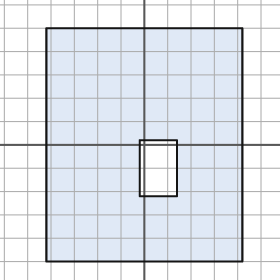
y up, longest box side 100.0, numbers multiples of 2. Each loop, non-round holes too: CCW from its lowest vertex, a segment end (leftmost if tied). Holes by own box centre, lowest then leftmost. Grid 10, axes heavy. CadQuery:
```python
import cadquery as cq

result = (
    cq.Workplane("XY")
    .moveTo(-42.0, -50.0)
    .lineTo(42.0, -50.0)
    .lineTo(42.0, 50.0)
    .lineTo(-42.0, 50.0)
    .close()
    .moveTo(-2.0, -22.0)
    .lineTo(14.0, -22.0)
    .lineTo(14.0, 2.0)
    .lineTo(-2.0, 2.0)
    .close()
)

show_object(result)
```